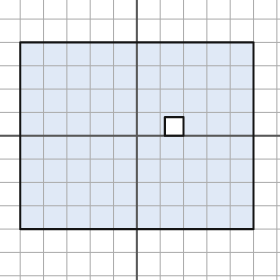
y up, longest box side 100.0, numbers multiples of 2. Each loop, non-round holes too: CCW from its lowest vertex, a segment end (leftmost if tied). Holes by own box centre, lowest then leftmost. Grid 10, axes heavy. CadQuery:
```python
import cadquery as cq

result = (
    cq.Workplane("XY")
    .moveTo(-50.0, -40.0)
    .lineTo(50.0, -40.0)
    .lineTo(50.0, 40.0)
    .lineTo(-50.0, 40.0)
    .close()
    .moveTo(12.0, 0.0)
    .lineTo(20.0, 0.0)
    .lineTo(20.0, 8.0)
    .lineTo(12.0, 8.0)
    .close()
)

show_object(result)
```